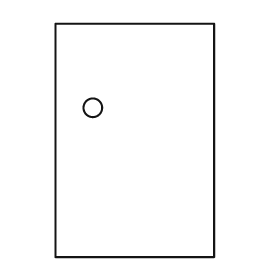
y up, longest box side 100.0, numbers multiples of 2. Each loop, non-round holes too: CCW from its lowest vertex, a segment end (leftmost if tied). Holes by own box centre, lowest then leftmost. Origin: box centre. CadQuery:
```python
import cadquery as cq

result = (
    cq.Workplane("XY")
    .moveTo(-34.0, -50.0)
    .lineTo(34.0, -50.0)
    .lineTo(34.0, 50.0)
    .lineTo(-34.0, 50.0)
    .close()
    .moveTo(-18.0, 14.0)
    .circle(4.0)
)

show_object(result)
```